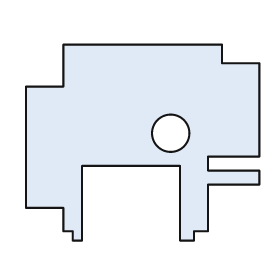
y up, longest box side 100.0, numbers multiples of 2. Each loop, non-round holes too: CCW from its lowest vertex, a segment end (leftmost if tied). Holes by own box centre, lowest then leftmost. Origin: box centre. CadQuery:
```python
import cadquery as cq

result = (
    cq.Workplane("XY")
    .moveTo(-30.0, -42.0)
    .lineTo(-26.0, -42.0)
    .lineTo(-26.0, -10.0)
    .lineTo(16.0, -10.0)
    .lineTo(16.0, -42.0)
    .lineTo(22.0, -42.0)
    .lineTo(22.0, -38.0)
    .lineTo(28.0, -38.0)
    .lineTo(28.0, -18.0)
    .lineTo(50.0, -18.0)
    .lineTo(50.0, -12.0)
    .lineTo(28.0, -12.0)
    .lineTo(28.0, -6.0)
    .lineTo(50.0, -6.0)
    .lineTo(50.0, 34.0)
    .lineTo(34.0, 34.0)
    .lineTo(34.0, 42.0)
    .lineTo(-34.0, 42.0)
    .lineTo(-34.0, 24.0)
    .lineTo(-50.0, 24.0)
    .lineTo(-50.0, -28.0)
    .lineTo(-34.0, -28.0)
    .lineTo(-34.0, -38.0)
    .lineTo(-30.0, -38.0)
    .close()
    .moveTo(12.0, 4.0)
    .circle(8.0)
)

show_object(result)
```